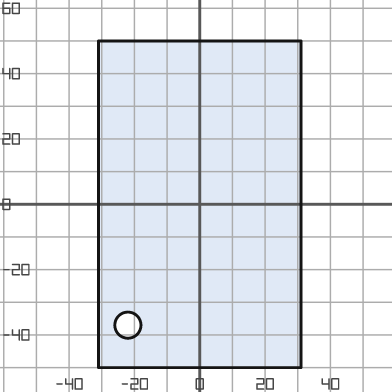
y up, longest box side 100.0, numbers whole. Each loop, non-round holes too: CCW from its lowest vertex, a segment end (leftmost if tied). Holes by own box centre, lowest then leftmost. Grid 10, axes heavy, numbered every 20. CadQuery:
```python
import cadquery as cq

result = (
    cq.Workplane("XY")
    .moveTo(-31.0, -50.0)
    .lineTo(31.0, -50.0)
    .lineTo(31.0, 50.0)
    .lineTo(-31.0, 50.0)
    .close()
    .moveTo(-22.0, -37.0)
    .circle(4.0)
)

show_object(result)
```